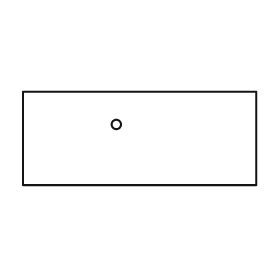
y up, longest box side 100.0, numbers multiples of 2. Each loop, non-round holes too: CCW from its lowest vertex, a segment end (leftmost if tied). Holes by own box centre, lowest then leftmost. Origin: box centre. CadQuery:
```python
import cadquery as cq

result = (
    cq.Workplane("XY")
    .moveTo(-50.0, -20.0)
    .lineTo(50.0, -20.0)
    .lineTo(50.0, 20.0)
    .lineTo(-50.0, 20.0)
    .close()
    .moveTo(-10.0, 6.0)
    .circle(2.0)
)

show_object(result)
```